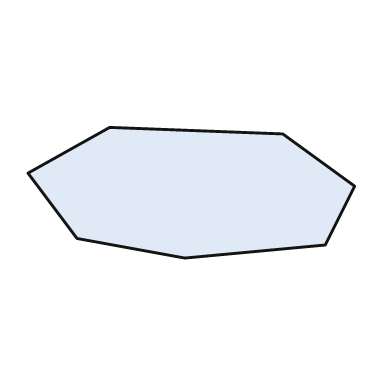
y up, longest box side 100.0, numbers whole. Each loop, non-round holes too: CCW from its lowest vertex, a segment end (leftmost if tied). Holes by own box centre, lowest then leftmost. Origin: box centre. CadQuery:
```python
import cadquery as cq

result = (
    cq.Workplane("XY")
    .moveTo(-2.0, -20.0)
    .lineTo(41.0, -16.0)
    .lineTo(50.0, 2.0)
    .lineTo(28.0, 18.0)
    .lineTo(-25.0, 20.0)
    .lineTo(-50.0, 6.0)
    .lineTo(-35.0, -14.0)
    .close()
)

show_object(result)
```